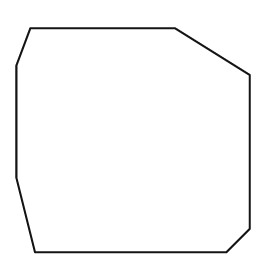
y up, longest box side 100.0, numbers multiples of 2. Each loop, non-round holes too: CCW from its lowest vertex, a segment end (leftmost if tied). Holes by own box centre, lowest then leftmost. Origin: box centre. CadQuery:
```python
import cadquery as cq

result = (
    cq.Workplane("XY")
    .moveTo(-42.0, -48.0)
    .lineTo(40.0, -48.0)
    .lineTo(50.0, -38.0)
    .lineTo(50.0, 28.0)
    .lineTo(18.0, 48.0)
    .lineTo(-44.0, 48.0)
    .lineTo(-50.0, 32.0)
    .lineTo(-50.0, -16.0)
    .close()
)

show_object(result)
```